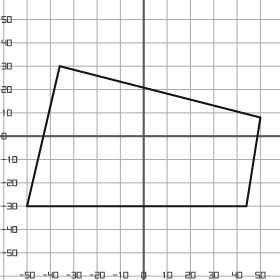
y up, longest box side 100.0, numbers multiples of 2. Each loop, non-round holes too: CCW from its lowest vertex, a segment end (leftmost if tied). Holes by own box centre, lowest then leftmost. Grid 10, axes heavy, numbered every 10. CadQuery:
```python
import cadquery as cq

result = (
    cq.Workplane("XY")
    .moveTo(-50.0, -30.0)
    .lineTo(44.0, -30.0)
    .lineTo(50.0, 8.0)
    .lineTo(-36.0, 30.0)
    .close()
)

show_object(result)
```